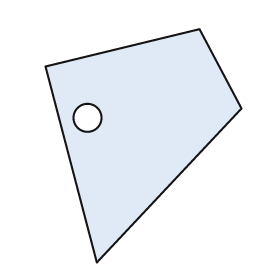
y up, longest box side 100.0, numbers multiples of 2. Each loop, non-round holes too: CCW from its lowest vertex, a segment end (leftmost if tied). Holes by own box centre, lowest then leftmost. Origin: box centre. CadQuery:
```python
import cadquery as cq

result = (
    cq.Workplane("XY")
    .moveTo(-20.0, -50.0)
    .lineTo(42.0, 16.0)
    .lineTo(24.0, 50.0)
    .lineTo(-42.0, 34.0)
    .close()
    .moveTo(-24.0, 12.0)
    .circle(6.0)
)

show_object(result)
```